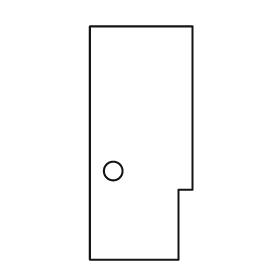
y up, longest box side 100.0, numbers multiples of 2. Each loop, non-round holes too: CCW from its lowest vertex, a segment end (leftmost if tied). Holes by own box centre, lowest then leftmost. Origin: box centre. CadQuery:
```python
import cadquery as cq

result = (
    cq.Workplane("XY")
    .moveTo(-22.0, -50.0)
    .lineTo(16.0, -50.0)
    .lineTo(16.0, -20.0)
    .lineTo(22.0, -20.0)
    .lineTo(22.0, 50.0)
    .lineTo(-22.0, 50.0)
    .close()
    .moveTo(-12.0, -12.0)
    .circle(4.0)
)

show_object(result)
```